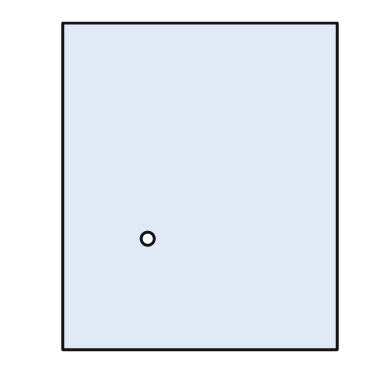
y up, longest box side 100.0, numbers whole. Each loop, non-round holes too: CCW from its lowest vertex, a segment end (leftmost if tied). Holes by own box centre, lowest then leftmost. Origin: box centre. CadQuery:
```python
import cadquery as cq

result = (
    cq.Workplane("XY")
    .moveTo(-42.0, -50.0)
    .lineTo(42.0, -50.0)
    .lineTo(42.0, 50.0)
    .lineTo(-42.0, 50.0)
    .close()
    .moveTo(-16.0, -16.0)
    .circle(2.0)
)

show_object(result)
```